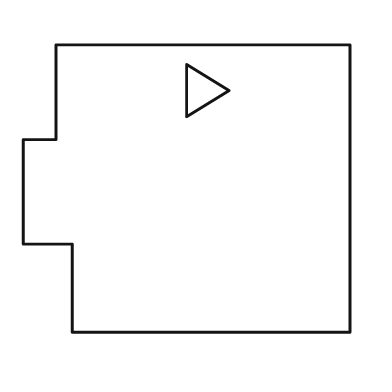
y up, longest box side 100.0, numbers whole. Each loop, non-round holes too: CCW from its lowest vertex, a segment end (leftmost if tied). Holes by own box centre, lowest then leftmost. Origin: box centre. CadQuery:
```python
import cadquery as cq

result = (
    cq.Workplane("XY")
    .moveTo(-35.0, -44.0)
    .lineTo(50.0, -44.0)
    .lineTo(50.0, 44.0)
    .lineTo(-40.0, 44.0)
    .lineTo(-40.0, 15.0)
    .lineTo(-50.0, 15.0)
    .lineTo(-50.0, -17.0)
    .lineTo(-35.0, -17.0)
    .close()
    .moveTo(0.0, 22.0)
    .lineTo(13.0, 30.0)
    .lineTo(0.0, 38.0)
    .close()
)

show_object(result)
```